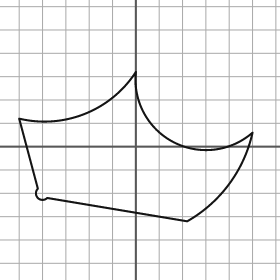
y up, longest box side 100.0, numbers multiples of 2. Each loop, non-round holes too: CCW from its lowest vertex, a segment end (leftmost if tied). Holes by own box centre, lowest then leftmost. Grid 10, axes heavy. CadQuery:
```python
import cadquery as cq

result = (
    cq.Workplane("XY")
    .moveTo(22.0, -32.0)
    .threePointArc((40.0, -16.0), (50.0, 6.0))
    .threePointArc((16.0, 2.0), (0.0, 32.0))
    .threePointArc((-22.0, 14.0), (-50.0, 12.0))
    .lineTo(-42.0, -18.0)
    .threePointArc((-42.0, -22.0), (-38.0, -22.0))
    .close()
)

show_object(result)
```